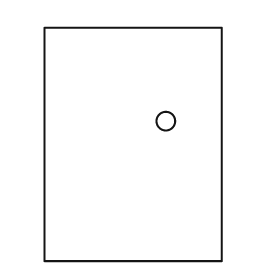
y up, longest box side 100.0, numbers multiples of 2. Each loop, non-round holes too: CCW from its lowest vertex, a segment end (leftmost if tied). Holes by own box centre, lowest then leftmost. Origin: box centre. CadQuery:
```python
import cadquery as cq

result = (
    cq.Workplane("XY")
    .moveTo(-38.0, -50.0)
    .lineTo(38.0, -50.0)
    .lineTo(38.0, 50.0)
    .lineTo(-38.0, 50.0)
    .close()
    .moveTo(14.0, 10.0)
    .circle(4.0)
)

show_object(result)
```